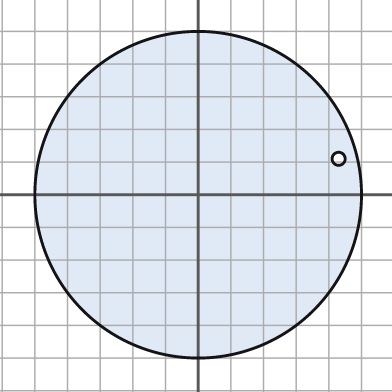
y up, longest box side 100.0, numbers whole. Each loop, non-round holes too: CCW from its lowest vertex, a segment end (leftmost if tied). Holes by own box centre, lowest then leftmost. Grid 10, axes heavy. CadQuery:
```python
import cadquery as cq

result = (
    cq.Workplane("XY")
    .moveTo(0.0, 0.0)
    .circle(50.0)
    .moveTo(43.0, 11.0)
    .circle(2.0)
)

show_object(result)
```